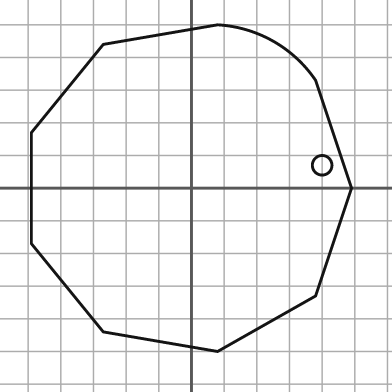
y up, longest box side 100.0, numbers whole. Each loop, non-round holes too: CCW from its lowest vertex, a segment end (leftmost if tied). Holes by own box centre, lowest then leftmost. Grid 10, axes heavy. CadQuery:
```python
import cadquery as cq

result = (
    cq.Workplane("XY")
    .moveTo(8.0, -50.0)
    .lineTo(38.0, -33.0)
    .lineTo(49.0, 0.0)
    .lineTo(38.0, 33.0)
    .threePointArc((25.0, 45.0), (8.0, 50.0))
    .lineTo(-27.0, 44.0)
    .lineTo(-49.0, 17.0)
    .lineTo(-49.0, -17.0)
    .lineTo(-27.0, -44.0)
    .close()
    .moveTo(40.0, 7.0)
    .circle(3.0)
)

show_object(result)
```